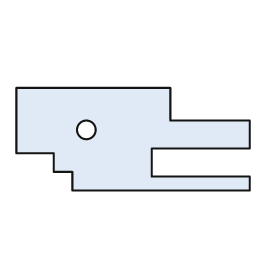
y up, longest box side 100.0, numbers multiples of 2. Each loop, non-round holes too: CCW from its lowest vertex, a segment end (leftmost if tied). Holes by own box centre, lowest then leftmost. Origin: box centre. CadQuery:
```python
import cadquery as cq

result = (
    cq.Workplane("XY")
    .moveTo(-26.0, -22.0)
    .lineTo(50.0, -22.0)
    .lineTo(50.0, -16.0)
    .lineTo(8.0, -16.0)
    .lineTo(8.0, -4.0)
    .lineTo(50.0, -4.0)
    .lineTo(50.0, 8.0)
    .lineTo(16.0, 8.0)
    .lineTo(16.0, 22.0)
    .lineTo(-50.0, 22.0)
    .lineTo(-50.0, -6.0)
    .lineTo(-34.0, -6.0)
    .lineTo(-34.0, -14.0)
    .lineTo(-26.0, -14.0)
    .close()
    .moveTo(-20.0, 4.0)
    .circle(4.0)
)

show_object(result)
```